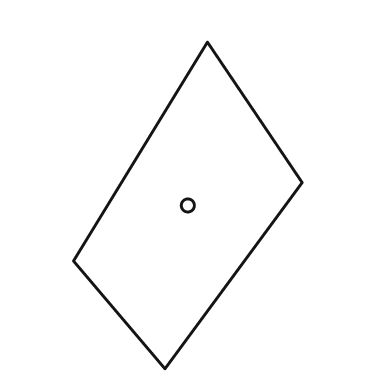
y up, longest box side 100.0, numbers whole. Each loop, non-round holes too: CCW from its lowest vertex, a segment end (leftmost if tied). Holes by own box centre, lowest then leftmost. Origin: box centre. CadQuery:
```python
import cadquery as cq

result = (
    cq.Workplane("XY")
    .moveTo(-7.0, -50.0)
    .lineTo(35.0, 7.0)
    .lineTo(6.0, 50.0)
    .lineTo(-35.0, -17.0)
    .close()
    .moveTo(0.0, 0.0)
    .circle(2.0)
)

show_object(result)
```